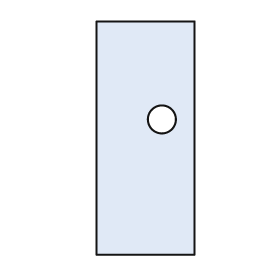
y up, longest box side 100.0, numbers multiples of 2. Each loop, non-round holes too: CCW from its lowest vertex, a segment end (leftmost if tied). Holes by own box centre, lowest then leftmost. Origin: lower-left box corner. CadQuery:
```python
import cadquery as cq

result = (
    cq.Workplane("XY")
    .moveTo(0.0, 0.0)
    .lineTo(42.0, 0.0)
    .lineTo(42.0, 100.0)
    .lineTo(0.0, 100.0)
    .close()
    .moveTo(28.0, 58.0)
    .circle(6.0)
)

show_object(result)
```